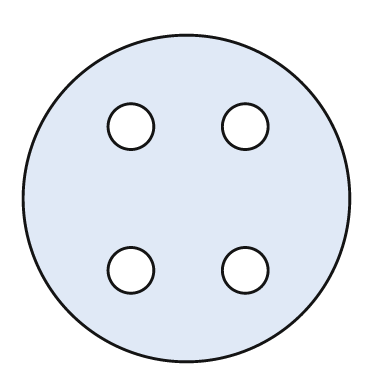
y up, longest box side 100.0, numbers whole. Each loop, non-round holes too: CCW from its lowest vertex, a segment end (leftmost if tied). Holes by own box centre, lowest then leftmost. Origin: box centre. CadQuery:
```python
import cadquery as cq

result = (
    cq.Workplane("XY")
    .moveTo(0.0, 0.0)
    .circle(50.0)
    .moveTo(-17.0, -22.0)
    .circle(7.0)
    .moveTo(18.0, -22.0)
    .circle(7.0)
    .moveTo(-17.0, 22.0)
    .circle(7.0)
    .moveTo(18.0, 22.0)
    .circle(7.0)
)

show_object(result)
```